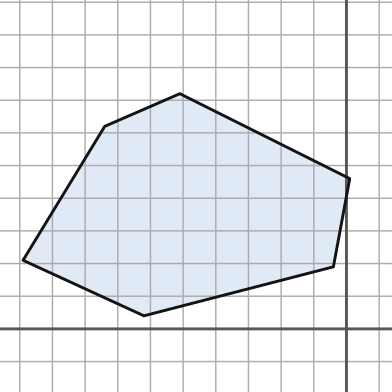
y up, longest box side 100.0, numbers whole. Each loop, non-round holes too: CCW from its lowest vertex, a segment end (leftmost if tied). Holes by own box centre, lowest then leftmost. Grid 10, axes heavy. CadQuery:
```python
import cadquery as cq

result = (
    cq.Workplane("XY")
    .moveTo(-62.0, 4.0)
    .lineTo(-4.0, 19.0)
    .lineTo(1.0, 46.0)
    .lineTo(-51.0, 72.0)
    .lineTo(-74.0, 62.0)
    .lineTo(-99.0, 21.0)
    .close()
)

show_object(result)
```